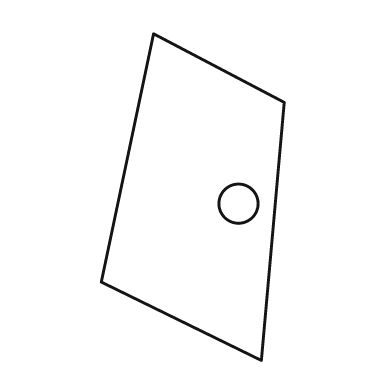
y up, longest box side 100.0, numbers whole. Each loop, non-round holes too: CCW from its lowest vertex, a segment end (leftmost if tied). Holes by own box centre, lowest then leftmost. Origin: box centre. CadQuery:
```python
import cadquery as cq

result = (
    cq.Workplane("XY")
    .moveTo(21.0, -50.0)
    .lineTo(28.0, 29.0)
    .lineTo(-12.0, 50.0)
    .lineTo(-28.0, -26.0)
    .close()
    .moveTo(14.0, -2.0)
    .circle(6.0)
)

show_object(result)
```